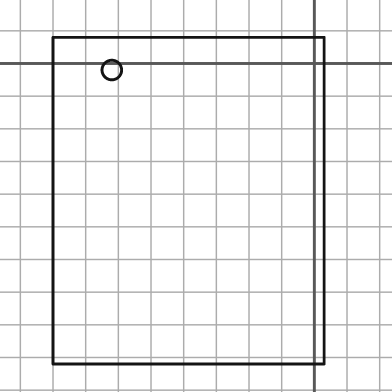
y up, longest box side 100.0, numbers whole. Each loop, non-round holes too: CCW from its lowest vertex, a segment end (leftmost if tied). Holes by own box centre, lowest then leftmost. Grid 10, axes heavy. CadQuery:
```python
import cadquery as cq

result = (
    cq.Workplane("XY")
    .moveTo(-80.0, -92.0)
    .lineTo(3.0, -92.0)
    .lineTo(3.0, 8.0)
    .lineTo(-80.0, 8.0)
    .close()
    .moveTo(-62.0, -2.0)
    .circle(3.0)
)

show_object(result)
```